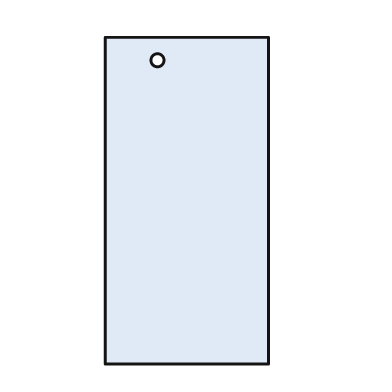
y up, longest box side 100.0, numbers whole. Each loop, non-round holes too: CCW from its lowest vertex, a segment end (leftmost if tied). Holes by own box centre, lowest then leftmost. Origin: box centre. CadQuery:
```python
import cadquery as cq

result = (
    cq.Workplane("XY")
    .moveTo(-25.0, -50.0)
    .lineTo(25.0, -50.0)
    .lineTo(25.0, 50.0)
    .lineTo(-25.0, 50.0)
    .close()
    .moveTo(-9.0, 43.0)
    .circle(2.0)
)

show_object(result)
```